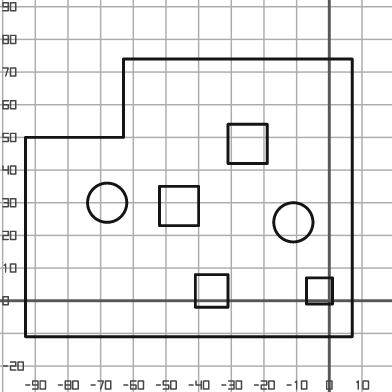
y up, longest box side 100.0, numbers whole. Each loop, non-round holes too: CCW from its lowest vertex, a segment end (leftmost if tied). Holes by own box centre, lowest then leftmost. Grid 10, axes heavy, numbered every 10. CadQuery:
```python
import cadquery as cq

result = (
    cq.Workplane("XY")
    .moveTo(-93.0, -11.0)
    .lineTo(7.0, -11.0)
    .lineTo(7.0, 74.0)
    .lineTo(-63.0, 74.0)
    .lineTo(-63.0, 50.0)
    .lineTo(-93.0, 50.0)
    .close()
    .moveTo(-41.0, -2.0)
    .lineTo(-31.0, -2.0)
    .lineTo(-31.0, 8.0)
    .lineTo(-41.0, 8.0)
    .close()
    .moveTo(-7.0, -1.0)
    .lineTo(1.0, -1.0)
    .lineTo(1.0, 7.0)
    .lineTo(-7.0, 7.0)
    .close()
    .moveTo(-11.0, 24.0)
    .circle(6.0)
    .moveTo(-52.0, 23.0)
    .lineTo(-40.0, 23.0)
    .lineTo(-40.0, 35.0)
    .lineTo(-52.0, 35.0)
    .close()
    .moveTo(-68.0, 30.0)
    .circle(6.0)
    .moveTo(-31.0, 42.0)
    .lineTo(-19.0, 42.0)
    .lineTo(-19.0, 54.0)
    .lineTo(-31.0, 54.0)
    .close()
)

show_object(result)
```